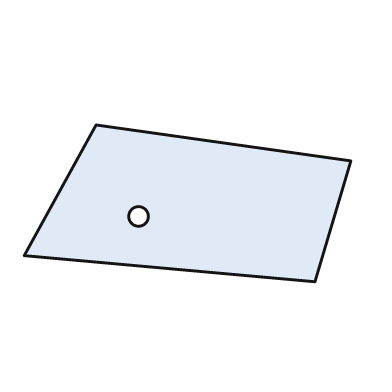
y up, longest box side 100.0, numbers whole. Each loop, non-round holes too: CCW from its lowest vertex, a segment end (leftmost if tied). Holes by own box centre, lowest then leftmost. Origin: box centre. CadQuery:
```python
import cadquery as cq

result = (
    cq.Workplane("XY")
    .moveTo(39.0, -24.0)
    .lineTo(50.0, 13.0)
    .lineTo(-28.0, 24.0)
    .lineTo(-50.0, -16.0)
    .close()
    .moveTo(-15.0, -4.0)
    .circle(3.0)
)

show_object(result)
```